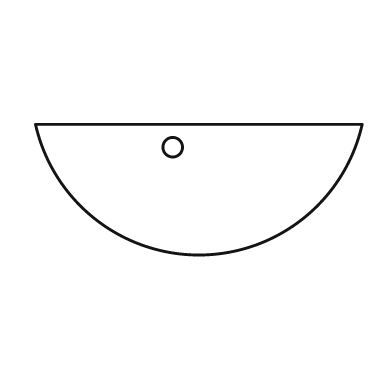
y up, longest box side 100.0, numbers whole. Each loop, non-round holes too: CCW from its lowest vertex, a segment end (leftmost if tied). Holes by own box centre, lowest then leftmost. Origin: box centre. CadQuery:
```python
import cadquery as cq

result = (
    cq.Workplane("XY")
    .moveTo(-50.0, 20.0)
    .threePointArc((0.0, -20.0), (50.0, 20.0))
    .close()
    .moveTo(-8.0, 13.0)
    .circle(3.0)
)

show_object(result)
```